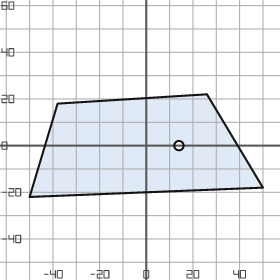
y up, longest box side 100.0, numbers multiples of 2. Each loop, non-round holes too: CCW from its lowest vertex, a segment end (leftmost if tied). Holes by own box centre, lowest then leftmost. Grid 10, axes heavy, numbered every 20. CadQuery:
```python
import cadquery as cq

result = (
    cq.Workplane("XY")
    .moveTo(-50.0, -22.0)
    .lineTo(50.0, -18.0)
    .lineTo(26.0, 22.0)
    .lineTo(-38.0, 18.0)
    .close()
    .moveTo(14.0, 0.0)
    .circle(2.0)
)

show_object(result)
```